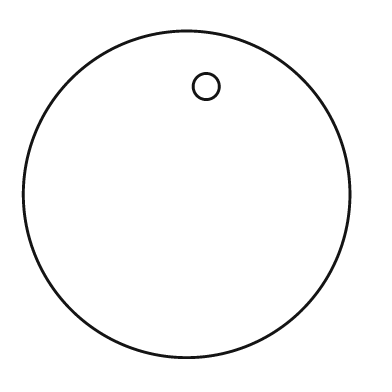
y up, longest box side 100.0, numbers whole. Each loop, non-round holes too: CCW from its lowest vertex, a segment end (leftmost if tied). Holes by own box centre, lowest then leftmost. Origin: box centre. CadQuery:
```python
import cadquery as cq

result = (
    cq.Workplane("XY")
    .moveTo(0.0, 0.0)
    .circle(50.0)
    .moveTo(6.0, 33.0)
    .circle(4.0)
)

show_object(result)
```